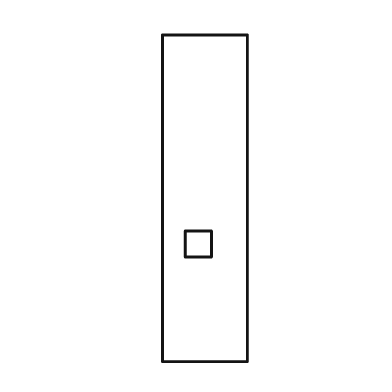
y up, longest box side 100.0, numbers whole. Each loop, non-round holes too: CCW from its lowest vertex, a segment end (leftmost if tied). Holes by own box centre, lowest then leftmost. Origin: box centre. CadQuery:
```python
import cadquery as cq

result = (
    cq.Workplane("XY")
    .moveTo(-13.0, -50.0)
    .lineTo(13.0, -50.0)
    .lineTo(13.0, 50.0)
    .lineTo(-13.0, 50.0)
    .close()
    .moveTo(-6.0, -18.0)
    .lineTo(2.0, -18.0)
    .lineTo(2.0, -10.0)
    .lineTo(-6.0, -10.0)
    .close()
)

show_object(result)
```